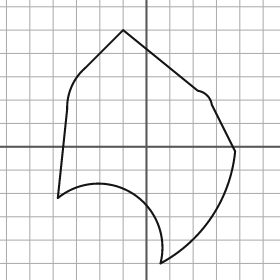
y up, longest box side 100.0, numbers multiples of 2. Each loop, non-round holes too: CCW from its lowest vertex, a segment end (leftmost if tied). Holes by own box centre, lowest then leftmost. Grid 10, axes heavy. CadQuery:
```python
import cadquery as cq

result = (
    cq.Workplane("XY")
    .moveTo(6.0, -50.0)
    .threePointArc((28.0, -30.0), (38.0, -2.0))
    .lineTo(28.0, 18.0)
    .threePointArc((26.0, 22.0), (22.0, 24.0))
    .lineTo(-10.0, 50.0)
    .lineTo(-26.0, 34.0)
    .threePointArc((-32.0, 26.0), (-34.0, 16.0))
    .lineTo(-38.0, -22.0)
    .threePointArc((-6.0, -20.0), (6.0, -50.0))
    .close()
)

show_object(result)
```